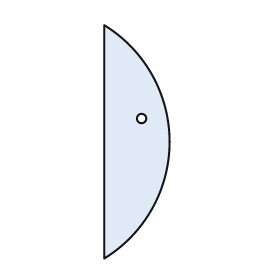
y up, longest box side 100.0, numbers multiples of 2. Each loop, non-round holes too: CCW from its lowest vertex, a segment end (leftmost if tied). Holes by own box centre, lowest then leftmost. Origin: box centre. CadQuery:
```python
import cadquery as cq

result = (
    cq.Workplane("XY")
    .moveTo(-14.0, -50.0)
    .threePointArc((14.0, 0.0), (-14.0, 50.0))
    .close()
    .moveTo(2.0, 10.0)
    .circle(2.0)
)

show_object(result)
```